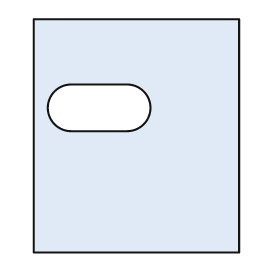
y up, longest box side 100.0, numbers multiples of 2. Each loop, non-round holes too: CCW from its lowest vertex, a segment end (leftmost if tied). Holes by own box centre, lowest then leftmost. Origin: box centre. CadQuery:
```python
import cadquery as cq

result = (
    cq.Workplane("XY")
    .moveTo(-44.0, -50.0)
    .lineTo(44.0, -50.0)
    .lineTo(44.0, 50.0)
    .lineTo(-44.0, 50.0)
    .close()
    .moveTo(-28.0, 2.0)
    .lineTo(-4.0, 2.0)
    .threePointArc((6.0, 12.0), (-4.0, 22.0))
    .lineTo(-28.0, 22.0)
    .threePointArc((-38.0, 12.0), (-28.0, 2.0))
    .close()
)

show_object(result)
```